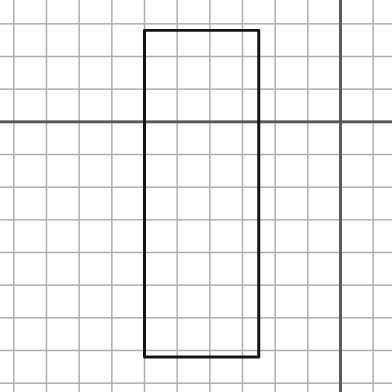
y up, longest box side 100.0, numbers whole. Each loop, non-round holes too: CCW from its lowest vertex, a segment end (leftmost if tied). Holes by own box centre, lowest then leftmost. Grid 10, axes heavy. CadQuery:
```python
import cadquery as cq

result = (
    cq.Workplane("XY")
    .moveTo(-60.0, -72.0)
    .lineTo(-25.0, -72.0)
    .lineTo(-25.0, 28.0)
    .lineTo(-60.0, 28.0)
    .close()
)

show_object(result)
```